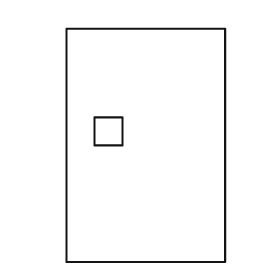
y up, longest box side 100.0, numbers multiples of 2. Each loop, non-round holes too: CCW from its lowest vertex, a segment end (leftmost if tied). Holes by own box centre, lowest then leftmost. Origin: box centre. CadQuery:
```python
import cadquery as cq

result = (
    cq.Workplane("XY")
    .moveTo(-34.0, -50.0)
    .lineTo(34.0, -50.0)
    .lineTo(34.0, 50.0)
    .lineTo(-34.0, 50.0)
    .close()
    .moveTo(-22.0, 0.0)
    .lineTo(-10.0, 0.0)
    .lineTo(-10.0, 12.0)
    .lineTo(-22.0, 12.0)
    .close()
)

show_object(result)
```